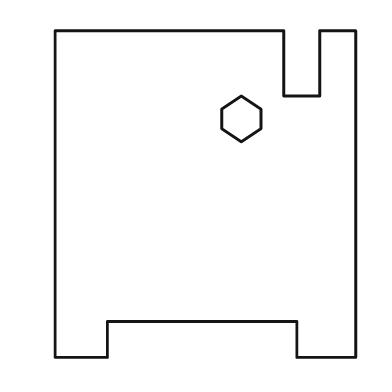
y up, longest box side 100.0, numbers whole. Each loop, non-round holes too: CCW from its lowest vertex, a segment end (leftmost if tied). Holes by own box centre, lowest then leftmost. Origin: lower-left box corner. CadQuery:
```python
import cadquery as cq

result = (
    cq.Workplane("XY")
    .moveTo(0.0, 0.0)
    .lineTo(16.0, 0.0)
    .lineTo(16.0, 11.0)
    .lineTo(74.0, 11.0)
    .lineTo(74.0, 0.0)
    .lineTo(92.0, 0.0)
    .lineTo(92.0, 100.0)
    .lineTo(81.0, 100.0)
    .lineTo(81.0, 80.0)
    .lineTo(70.0, 80.0)
    .lineTo(70.0, 100.0)
    .lineTo(0.0, 100.0)
    .close()
    .moveTo(57.0, 66.0)
    .lineTo(63.0, 70.0)
    .lineTo(63.0, 76.0)
    .lineTo(57.0, 80.0)
    .lineTo(51.0, 76.0)
    .lineTo(51.0, 70.0)
    .close()
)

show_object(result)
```